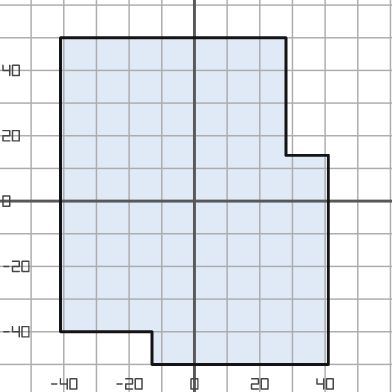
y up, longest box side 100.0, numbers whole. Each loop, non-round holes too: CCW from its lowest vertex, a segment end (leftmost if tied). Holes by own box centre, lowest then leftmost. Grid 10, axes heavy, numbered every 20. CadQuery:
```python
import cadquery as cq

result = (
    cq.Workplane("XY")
    .moveTo(-13.0, -50.0)
    .lineTo(41.0, -50.0)
    .lineTo(41.0, 14.0)
    .lineTo(28.0, 14.0)
    .lineTo(28.0, 50.0)
    .lineTo(-41.0, 50.0)
    .lineTo(-41.0, -40.0)
    .lineTo(-13.0, -40.0)
    .close()
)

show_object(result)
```